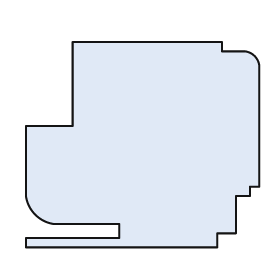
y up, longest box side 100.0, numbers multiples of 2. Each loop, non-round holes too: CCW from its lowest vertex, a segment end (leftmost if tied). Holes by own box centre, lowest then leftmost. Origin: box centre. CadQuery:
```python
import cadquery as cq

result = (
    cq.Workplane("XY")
    .moveTo(-50.0, -44.0)
    .lineTo(32.0, -44.0)
    .lineTo(32.0, -38.0)
    .lineTo(40.0, -38.0)
    .lineTo(40.0, -22.0)
    .lineTo(46.0, -22.0)
    .lineTo(46.0, -18.0)
    .lineTo(50.0, -18.0)
    .lineTo(50.0, 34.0)
    .threePointArc((48.0, 38.0), (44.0, 40.0))
    .lineTo(34.0, 40.0)
    .lineTo(34.0, 44.0)
    .lineTo(-30.0, 44.0)
    .lineTo(-30.0, 8.0)
    .lineTo(-50.0, 8.0)
    .lineTo(-50.0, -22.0)
    .threePointArc((-46.0, -30.0), (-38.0, -34.0))
    .lineTo(-10.0, -34.0)
    .lineTo(-10.0, -40.0)
    .lineTo(-50.0, -40.0)
    .close()
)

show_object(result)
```